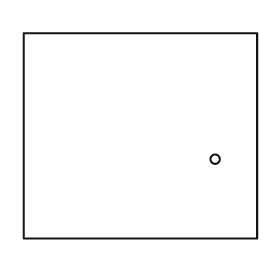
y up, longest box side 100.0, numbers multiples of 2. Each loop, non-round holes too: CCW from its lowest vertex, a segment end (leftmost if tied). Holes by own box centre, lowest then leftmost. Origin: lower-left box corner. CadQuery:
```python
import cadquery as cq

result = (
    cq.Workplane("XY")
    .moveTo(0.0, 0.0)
    .lineTo(100.0, 0.0)
    .lineTo(100.0, 88.0)
    .lineTo(0.0, 88.0)
    .close()
    .moveTo(82.0, 34.0)
    .circle(2.0)
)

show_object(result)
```